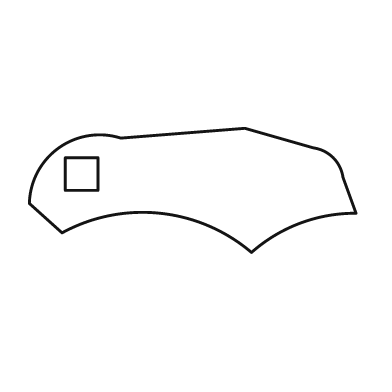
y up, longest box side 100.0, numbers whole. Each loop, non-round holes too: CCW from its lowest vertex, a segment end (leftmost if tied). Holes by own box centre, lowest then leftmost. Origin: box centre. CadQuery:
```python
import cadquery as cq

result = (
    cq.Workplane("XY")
    .moveTo(18.0, -19.0)
    .threePointArc((33.0, -10.0), (50.0, -7.0))
    .lineTo(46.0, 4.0)
    .threePointArc((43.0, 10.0), (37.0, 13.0))
    .lineTo(16.0, 19.0)
    .lineTo(-22.0, 16.0)
    .threePointArc((-41.0, 13.0), (-50.0, -4.0))
    .lineTo(-40.0, -13.0)
    .threePointArc((-10.0, -7.0), (18.0, -19.0))
    .close()
    .moveTo(-39.0, 0.0)
    .lineTo(-29.0, 0.0)
    .lineTo(-29.0, 10.0)
    .lineTo(-39.0, 10.0)
    .close()
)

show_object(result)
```